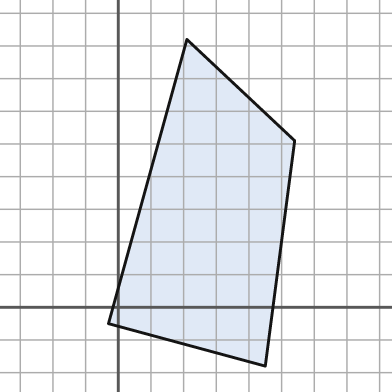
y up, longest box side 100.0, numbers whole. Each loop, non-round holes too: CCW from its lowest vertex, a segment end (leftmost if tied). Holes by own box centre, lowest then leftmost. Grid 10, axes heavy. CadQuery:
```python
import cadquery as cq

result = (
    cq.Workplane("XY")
    .moveTo(45.0, -18.0)
    .lineTo(54.0, 51.0)
    .lineTo(21.0, 82.0)
    .lineTo(-3.0, -5.0)
    .close()
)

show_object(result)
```